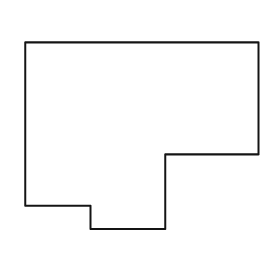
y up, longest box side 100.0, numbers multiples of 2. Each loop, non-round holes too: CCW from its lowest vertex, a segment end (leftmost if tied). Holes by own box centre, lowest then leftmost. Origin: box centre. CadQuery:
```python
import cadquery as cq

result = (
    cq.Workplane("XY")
    .moveTo(-22.0, -40.0)
    .lineTo(10.0, -40.0)
    .lineTo(10.0, -8.0)
    .lineTo(50.0, -8.0)
    .lineTo(50.0, 40.0)
    .lineTo(-50.0, 40.0)
    .lineTo(-50.0, -30.0)
    .lineTo(-22.0, -30.0)
    .close()
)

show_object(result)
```